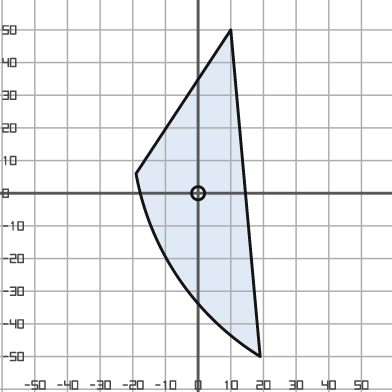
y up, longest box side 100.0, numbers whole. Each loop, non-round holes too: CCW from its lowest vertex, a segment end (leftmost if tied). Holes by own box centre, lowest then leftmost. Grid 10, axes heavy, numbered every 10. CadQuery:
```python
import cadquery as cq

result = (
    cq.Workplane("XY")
    .moveTo(19.0, -50.0)
    .lineTo(10.0, 50.0)
    .lineTo(-19.0, 6.0)
    .threePointArc((-6.0, -26.0), (19.0, -50.0))
    .close()
    .moveTo(0.0, 0.0)
    .circle(2.0)
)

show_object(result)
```